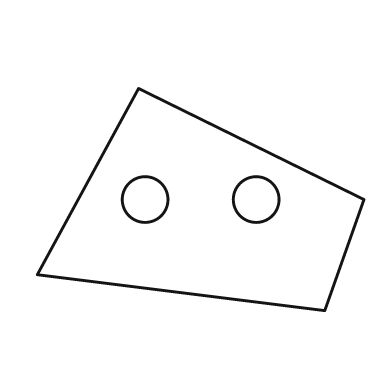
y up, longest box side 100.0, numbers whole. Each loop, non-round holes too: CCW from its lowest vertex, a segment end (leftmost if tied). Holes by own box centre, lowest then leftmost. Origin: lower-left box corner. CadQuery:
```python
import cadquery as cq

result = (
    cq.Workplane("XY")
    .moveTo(88.0, 0.0)
    .lineTo(100.0, 34.0)
    .lineTo(31.0, 68.0)
    .lineTo(0.0, 11.0)
    .close()
    .moveTo(33.0, 34.0)
    .circle(7.0)
    .moveTo(67.0, 34.0)
    .circle(7.0)
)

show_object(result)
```